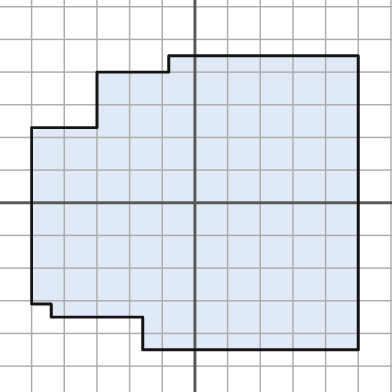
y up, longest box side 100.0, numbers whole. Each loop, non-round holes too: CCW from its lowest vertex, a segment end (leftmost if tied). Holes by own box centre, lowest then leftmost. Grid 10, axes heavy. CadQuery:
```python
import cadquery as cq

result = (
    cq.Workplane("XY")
    .moveTo(-16.0, -45.0)
    .lineTo(50.0, -45.0)
    .lineTo(50.0, 45.0)
    .lineTo(-8.0, 45.0)
    .lineTo(-8.0, 40.0)
    .lineTo(-30.0, 40.0)
    .lineTo(-30.0, 23.0)
    .lineTo(-50.0, 23.0)
    .lineTo(-50.0, -31.0)
    .lineTo(-44.0, -31.0)
    .lineTo(-44.0, -35.0)
    .lineTo(-16.0, -35.0)
    .close()
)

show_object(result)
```